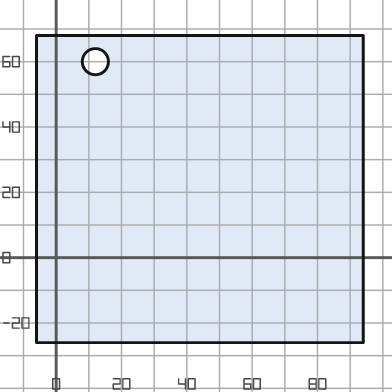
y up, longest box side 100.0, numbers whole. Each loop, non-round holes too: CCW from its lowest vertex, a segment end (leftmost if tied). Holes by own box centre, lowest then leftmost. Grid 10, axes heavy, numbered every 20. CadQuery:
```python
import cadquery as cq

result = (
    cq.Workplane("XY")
    .moveTo(-6.0, -26.0)
    .lineTo(94.0, -26.0)
    .lineTo(94.0, 68.0)
    .lineTo(-6.0, 68.0)
    .close()
    .moveTo(12.0, 60.0)
    .circle(4.0)
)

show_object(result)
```